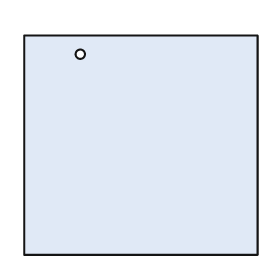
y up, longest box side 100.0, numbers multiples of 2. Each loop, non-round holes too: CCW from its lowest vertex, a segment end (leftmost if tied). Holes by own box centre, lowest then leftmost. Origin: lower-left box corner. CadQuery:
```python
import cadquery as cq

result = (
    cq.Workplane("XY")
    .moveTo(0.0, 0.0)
    .lineTo(100.0, 0.0)
    .lineTo(100.0, 94.0)
    .lineTo(0.0, 94.0)
    .close()
    .moveTo(24.0, 86.0)
    .circle(2.0)
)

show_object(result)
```